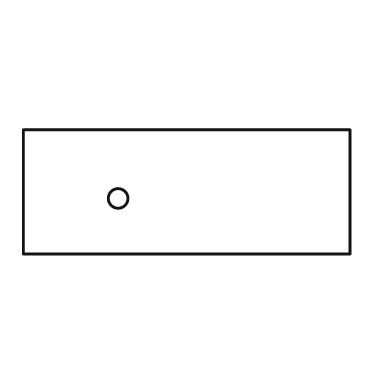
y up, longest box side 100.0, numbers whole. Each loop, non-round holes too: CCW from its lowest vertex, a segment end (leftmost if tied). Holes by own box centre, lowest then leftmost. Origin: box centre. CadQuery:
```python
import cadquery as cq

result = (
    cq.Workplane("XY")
    .moveTo(-50.0, -19.0)
    .lineTo(50.0, -19.0)
    .lineTo(50.0, 19.0)
    .lineTo(-50.0, 19.0)
    .close()
    .moveTo(-21.0, -2.0)
    .circle(3.0)
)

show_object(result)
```